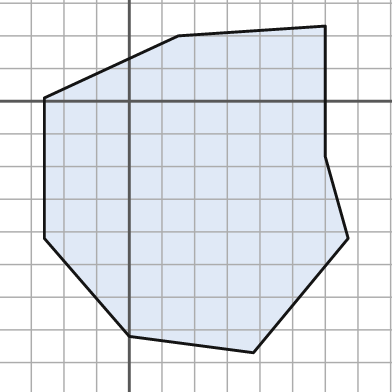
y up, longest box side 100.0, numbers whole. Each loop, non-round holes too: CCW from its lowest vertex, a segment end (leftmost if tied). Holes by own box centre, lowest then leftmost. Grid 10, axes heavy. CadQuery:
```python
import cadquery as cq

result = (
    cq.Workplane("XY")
    .moveTo(38.0, -77.0)
    .lineTo(67.0, -42.0)
    .lineTo(60.0, -17.0)
    .lineTo(60.0, 23.0)
    .lineTo(15.0, 20.0)
    .lineTo(-26.0, 1.0)
    .lineTo(-26.0, -42.0)
    .lineTo(0.0, -72.0)
    .close()
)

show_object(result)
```